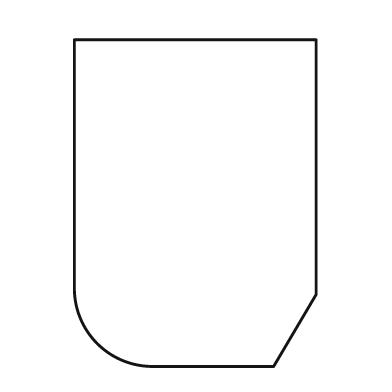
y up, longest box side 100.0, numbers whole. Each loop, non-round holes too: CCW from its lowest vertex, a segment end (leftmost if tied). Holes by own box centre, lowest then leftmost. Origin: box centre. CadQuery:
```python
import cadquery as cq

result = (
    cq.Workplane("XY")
    .moveTo(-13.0, -50.0)
    .lineTo(24.0, -50.0)
    .lineTo(37.0, -28.0)
    .lineTo(37.0, 50.0)
    .lineTo(-37.0, 50.0)
    .lineTo(-37.0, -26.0)
    .threePointArc((-30.0, -43.0), (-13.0, -50.0))
    .close()
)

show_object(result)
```